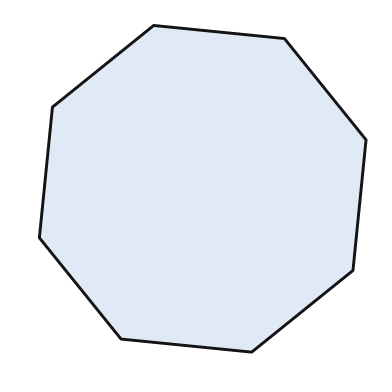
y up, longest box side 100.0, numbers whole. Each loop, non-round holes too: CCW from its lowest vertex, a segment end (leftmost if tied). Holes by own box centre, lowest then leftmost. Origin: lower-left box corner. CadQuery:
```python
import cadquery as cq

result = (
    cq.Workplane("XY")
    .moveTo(65.0, 0.0)
    .lineTo(96.0, 25.0)
    .lineTo(100.0, 65.0)
    .lineTo(75.0, 96.0)
    .lineTo(35.0, 100.0)
    .lineTo(4.0, 75.0)
    .lineTo(0.0, 35.0)
    .lineTo(25.0, 4.0)
    .close()
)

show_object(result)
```